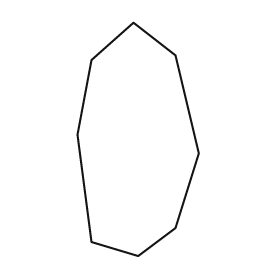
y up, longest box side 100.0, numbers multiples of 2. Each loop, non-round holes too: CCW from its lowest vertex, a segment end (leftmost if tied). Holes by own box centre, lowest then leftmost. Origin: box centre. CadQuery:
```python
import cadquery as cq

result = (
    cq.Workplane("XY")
    .moveTo(0.0, -50.0)
    .lineTo(16.0, -38.0)
    .lineTo(26.0, -6.0)
    .lineTo(16.0, 36.0)
    .lineTo(-2.0, 50.0)
    .lineTo(-20.0, 34.0)
    .lineTo(-26.0, 2.0)
    .lineTo(-20.0, -44.0)
    .close()
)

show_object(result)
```